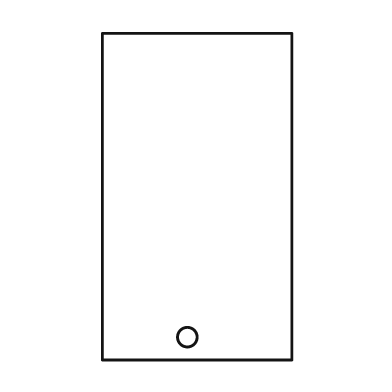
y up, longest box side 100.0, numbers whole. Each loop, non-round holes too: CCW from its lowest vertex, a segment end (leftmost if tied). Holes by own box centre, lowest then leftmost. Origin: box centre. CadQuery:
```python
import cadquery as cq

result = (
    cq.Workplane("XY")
    .moveTo(-29.0, -50.0)
    .lineTo(29.0, -50.0)
    .lineTo(29.0, 50.0)
    .lineTo(-29.0, 50.0)
    .close()
    .moveTo(-3.0, -43.0)
    .circle(3.0)
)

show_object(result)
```